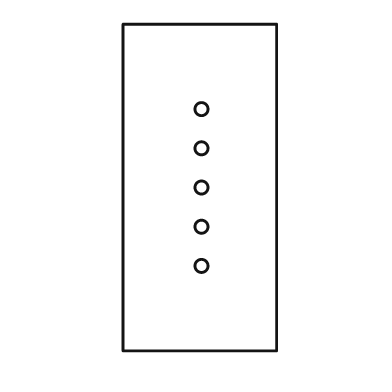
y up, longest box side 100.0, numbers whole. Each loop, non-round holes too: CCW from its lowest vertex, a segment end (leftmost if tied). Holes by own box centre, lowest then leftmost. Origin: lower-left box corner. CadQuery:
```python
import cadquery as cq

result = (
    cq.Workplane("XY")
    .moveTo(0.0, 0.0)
    .lineTo(47.0, 0.0)
    .lineTo(47.0, 100.0)
    .lineTo(0.0, 100.0)
    .close()
    .moveTo(24.0, 26.0)
    .circle(2.0)
    .moveTo(24.0, 38.0)
    .circle(2.0)
    .moveTo(24.0, 50.0)
    .circle(2.0)
    .moveTo(24.0, 62.0)
    .circle(2.0)
    .moveTo(24.0, 74.0)
    .circle(2.0)
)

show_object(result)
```